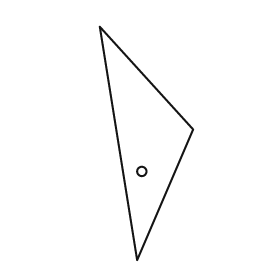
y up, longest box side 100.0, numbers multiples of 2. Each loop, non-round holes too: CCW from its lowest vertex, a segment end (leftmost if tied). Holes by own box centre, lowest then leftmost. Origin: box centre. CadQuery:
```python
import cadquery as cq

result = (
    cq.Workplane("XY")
    .moveTo(-4.0, -50.0)
    .lineTo(20.0, 6.0)
    .lineTo(-20.0, 50.0)
    .close()
    .moveTo(-2.0, -12.0)
    .circle(2.0)
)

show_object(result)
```